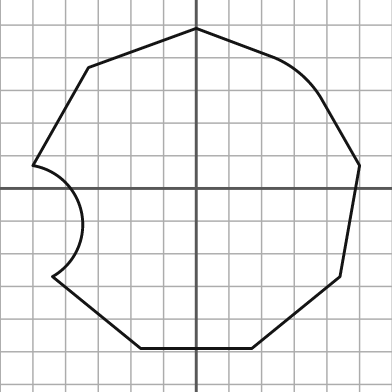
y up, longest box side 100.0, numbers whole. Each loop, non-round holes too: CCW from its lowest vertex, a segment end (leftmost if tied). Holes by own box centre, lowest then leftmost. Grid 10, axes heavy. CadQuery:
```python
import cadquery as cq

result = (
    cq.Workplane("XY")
    .moveTo(-17.0, -49.0)
    .lineTo(17.0, -49.0)
    .lineTo(44.0, -27.0)
    .lineTo(50.0, 7.0)
    .lineTo(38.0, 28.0)
    .threePointArc((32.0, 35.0), (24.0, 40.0))
    .lineTo(0.0, 49.0)
    .lineTo(-33.0, 37.0)
    .lineTo(-50.0, 7.0)
    .threePointArc((-35.0, -8.0), (-44.0, -27.0))
    .close()
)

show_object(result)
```